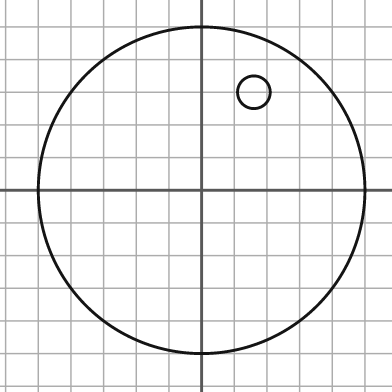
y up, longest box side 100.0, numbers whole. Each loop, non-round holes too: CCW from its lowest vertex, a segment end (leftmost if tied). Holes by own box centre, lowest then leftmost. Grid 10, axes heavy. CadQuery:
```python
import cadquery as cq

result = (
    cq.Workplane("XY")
    .moveTo(0.0, 0.0)
    .circle(50.0)
    .moveTo(16.0, 30.0)
    .circle(5.0)
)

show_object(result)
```